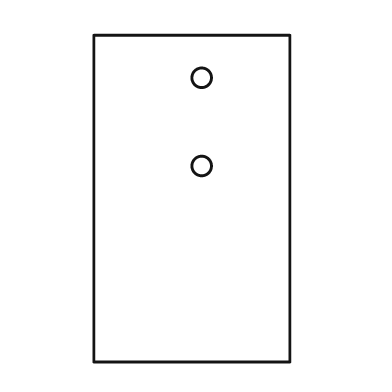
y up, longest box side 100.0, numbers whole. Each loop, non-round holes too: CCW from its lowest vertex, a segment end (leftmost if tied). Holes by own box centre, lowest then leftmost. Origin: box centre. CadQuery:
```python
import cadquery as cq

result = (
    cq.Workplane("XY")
    .moveTo(-30.0, -50.0)
    .lineTo(30.0, -50.0)
    .lineTo(30.0, 50.0)
    .lineTo(-30.0, 50.0)
    .close()
    .moveTo(3.0, 10.0)
    .circle(3.0)
    .moveTo(3.0, 37.0)
    .circle(3.0)
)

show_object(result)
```